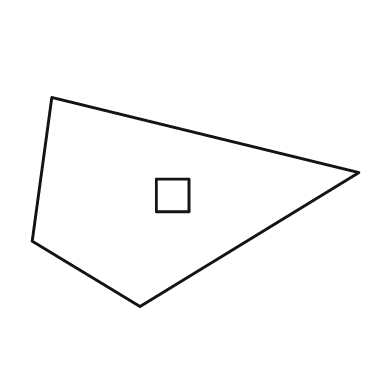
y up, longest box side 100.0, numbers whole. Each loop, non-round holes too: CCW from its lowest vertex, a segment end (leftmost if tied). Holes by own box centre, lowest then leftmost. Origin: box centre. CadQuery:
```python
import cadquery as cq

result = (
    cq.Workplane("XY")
    .moveTo(-17.0, -32.0)
    .lineTo(50.0, 9.0)
    .lineTo(-44.0, 32.0)
    .lineTo(-50.0, -12.0)
    .close()
    .moveTo(-12.0, -3.0)
    .lineTo(-2.0, -3.0)
    .lineTo(-2.0, 7.0)
    .lineTo(-12.0, 7.0)
    .close()
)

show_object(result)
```